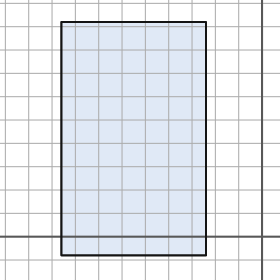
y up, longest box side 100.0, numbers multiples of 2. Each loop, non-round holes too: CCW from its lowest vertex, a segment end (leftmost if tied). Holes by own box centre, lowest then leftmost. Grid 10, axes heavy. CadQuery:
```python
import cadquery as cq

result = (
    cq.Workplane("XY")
    .moveTo(-86.0, -8.0)
    .lineTo(-24.0, -8.0)
    .lineTo(-24.0, 92.0)
    .lineTo(-86.0, 92.0)
    .close()
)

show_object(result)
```